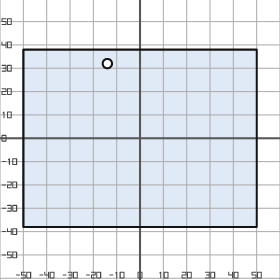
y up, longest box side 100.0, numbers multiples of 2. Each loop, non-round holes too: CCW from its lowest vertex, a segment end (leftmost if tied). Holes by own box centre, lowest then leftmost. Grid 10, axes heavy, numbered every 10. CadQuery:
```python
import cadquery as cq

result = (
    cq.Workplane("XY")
    .moveTo(-50.0, -38.0)
    .lineTo(50.0, -38.0)
    .lineTo(50.0, 38.0)
    .lineTo(-50.0, 38.0)
    .close()
    .moveTo(-14.0, 32.0)
    .circle(2.0)
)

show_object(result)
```